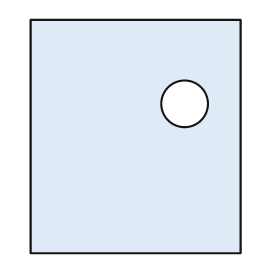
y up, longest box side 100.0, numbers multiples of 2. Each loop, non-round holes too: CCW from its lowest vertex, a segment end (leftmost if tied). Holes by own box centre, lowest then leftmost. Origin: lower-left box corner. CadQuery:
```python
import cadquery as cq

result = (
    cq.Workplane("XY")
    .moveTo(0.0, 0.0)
    .lineTo(90.0, 0.0)
    .lineTo(90.0, 100.0)
    .lineTo(0.0, 100.0)
    .close()
    .moveTo(66.0, 64.0)
    .circle(10.0)
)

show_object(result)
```